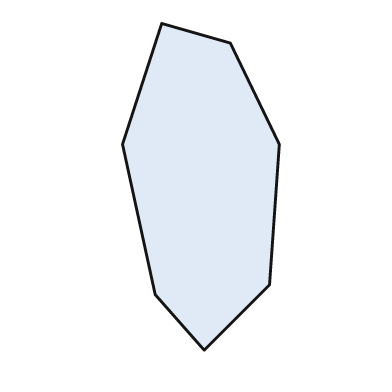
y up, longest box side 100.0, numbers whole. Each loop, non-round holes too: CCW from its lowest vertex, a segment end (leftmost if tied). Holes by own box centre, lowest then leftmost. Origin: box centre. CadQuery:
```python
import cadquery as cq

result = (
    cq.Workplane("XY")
    .moveTo(1.0, -50.0)
    .lineTo(21.0, -30.0)
    .lineTo(24.0, 13.0)
    .lineTo(9.0, 44.0)
    .lineTo(-12.0, 50.0)
    .lineTo(-24.0, 13.0)
    .lineTo(-14.0, -33.0)
    .close()
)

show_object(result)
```